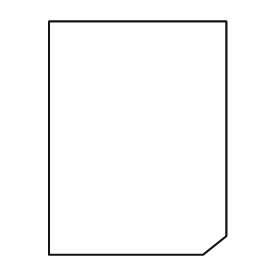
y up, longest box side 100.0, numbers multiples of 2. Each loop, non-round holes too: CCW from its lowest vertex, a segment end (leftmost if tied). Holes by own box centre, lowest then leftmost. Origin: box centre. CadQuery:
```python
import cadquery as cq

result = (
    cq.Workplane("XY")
    .moveTo(-38.0, -50.0)
    .lineTo(28.0, -50.0)
    .lineTo(38.0, -42.0)
    .lineTo(38.0, 50.0)
    .lineTo(-38.0, 50.0)
    .close()
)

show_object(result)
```